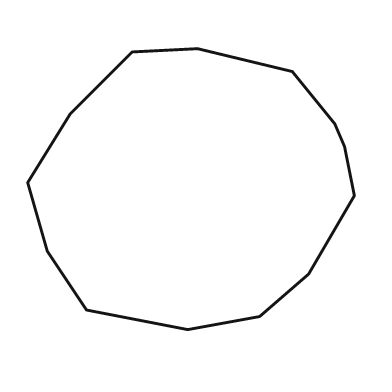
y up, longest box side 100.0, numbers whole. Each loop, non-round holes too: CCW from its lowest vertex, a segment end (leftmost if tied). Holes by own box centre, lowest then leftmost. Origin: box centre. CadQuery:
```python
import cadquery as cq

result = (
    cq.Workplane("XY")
    .moveTo(-1.0, -43.0)
    .lineTo(21.0, -39.0)
    .lineTo(36.0, -26.0)
    .lineTo(50.0, -2.0)
    .lineTo(47.0, 13.0)
    .lineTo(44.0, 20.0)
    .lineTo(31.0, 36.0)
    .lineTo(2.0, 43.0)
    .lineTo(-18.0, 42.0)
    .lineTo(-37.0, 23.0)
    .lineTo(-50.0, 2.0)
    .lineTo(-44.0, -19.0)
    .lineTo(-32.0, -37.0)
    .close()
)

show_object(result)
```